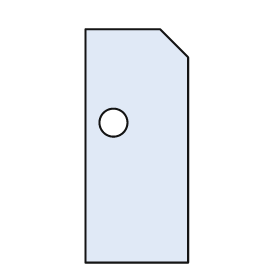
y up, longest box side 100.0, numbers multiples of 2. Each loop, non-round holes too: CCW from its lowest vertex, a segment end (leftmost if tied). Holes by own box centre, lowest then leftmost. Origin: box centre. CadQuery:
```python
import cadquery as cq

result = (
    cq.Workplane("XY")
    .moveTo(-22.0, -50.0)
    .lineTo(22.0, -50.0)
    .lineTo(22.0, 38.0)
    .lineTo(10.0, 50.0)
    .lineTo(-22.0, 50.0)
    .close()
    .moveTo(-10.0, 10.0)
    .circle(6.0)
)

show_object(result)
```